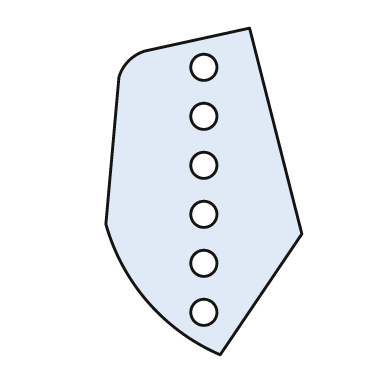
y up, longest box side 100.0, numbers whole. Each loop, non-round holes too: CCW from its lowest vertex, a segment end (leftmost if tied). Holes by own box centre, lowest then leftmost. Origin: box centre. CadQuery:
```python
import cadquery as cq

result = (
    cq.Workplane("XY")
    .moveTo(5.0, -50.0)
    .lineTo(30.0, -13.0)
    .lineTo(14.0, 50.0)
    .lineTo(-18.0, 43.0)
    .threePointArc((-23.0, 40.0), (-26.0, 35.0))
    .lineTo(-30.0, -10.0)
    .threePointArc((-17.0, -34.0), (5.0, -50.0))
    .close()
    .moveTo(0.0, -37.0)
    .circle(4.0)
    .moveTo(0.0, -22.0)
    .circle(4.0)
    .moveTo(0.0, -7.0)
    .circle(4.0)
    .moveTo(0.0, 8.0)
    .circle(4.0)
    .moveTo(0.0, 23.0)
    .circle(4.0)
    .moveTo(0.0, 38.0)
    .circle(4.0)
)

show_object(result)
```